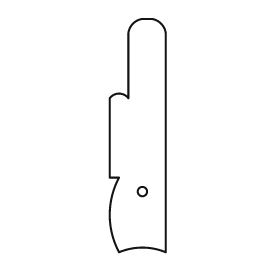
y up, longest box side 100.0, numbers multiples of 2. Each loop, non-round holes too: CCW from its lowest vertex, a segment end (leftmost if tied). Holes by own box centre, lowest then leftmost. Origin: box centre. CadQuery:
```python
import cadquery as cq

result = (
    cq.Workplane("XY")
    .moveTo(-8.0, -50.0)
    .threePointArc((2.0, -48.0), (12.0, -50.0))
    .lineTo(12.0, 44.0)
    .threePointArc((10.0, 48.0), (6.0, 50.0))
    .lineTo(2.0, 50.0)
    .threePointArc((-2.0, 48.0), (-4.0, 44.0))
    .lineTo(-4.0, 16.0)
    .threePointArc((-8.0, 18.0), (-12.0, 16.0))
    .lineTo(-12.0, -18.0)
    .lineTo(-8.0, -18.0)
    .threePointArc((-12.0, -34.0), (-8.0, -50.0))
    .close()
    .moveTo(2.0, -24.0)
    .circle(2.0)
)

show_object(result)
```